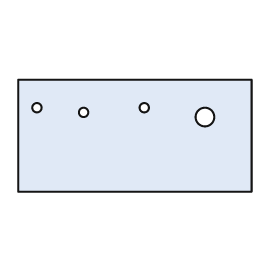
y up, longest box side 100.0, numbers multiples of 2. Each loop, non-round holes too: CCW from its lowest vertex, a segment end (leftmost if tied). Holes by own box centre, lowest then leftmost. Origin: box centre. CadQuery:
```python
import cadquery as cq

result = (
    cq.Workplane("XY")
    .moveTo(-50.0, -24.0)
    .lineTo(50.0, -24.0)
    .lineTo(50.0, 24.0)
    .lineTo(-50.0, 24.0)
    .close()
    .moveTo(30.0, 8.0)
    .circle(4.0)
    .moveTo(-22.0, 10.0)
    .circle(2.0)
    .moveTo(-42.0, 12.0)
    .circle(2.0)
    .moveTo(4.0, 12.0)
    .circle(2.0)
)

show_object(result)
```